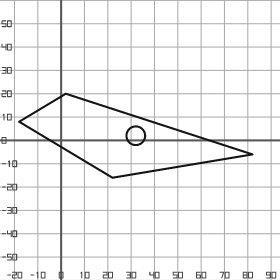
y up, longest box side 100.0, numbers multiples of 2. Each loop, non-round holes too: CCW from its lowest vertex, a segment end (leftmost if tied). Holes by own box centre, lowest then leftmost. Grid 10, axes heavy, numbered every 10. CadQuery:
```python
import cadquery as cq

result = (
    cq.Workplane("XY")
    .moveTo(22.0, -16.0)
    .lineTo(82.0, -6.0)
    .lineTo(2.0, 20.0)
    .lineTo(-18.0, 8.0)
    .close()
    .moveTo(32.0, 2.0)
    .circle(4.0)
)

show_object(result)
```